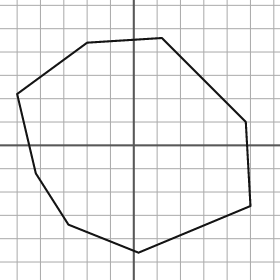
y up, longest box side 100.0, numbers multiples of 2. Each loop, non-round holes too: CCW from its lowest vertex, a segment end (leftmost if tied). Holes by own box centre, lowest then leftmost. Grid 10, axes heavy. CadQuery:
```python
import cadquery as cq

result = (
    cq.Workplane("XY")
    .moveTo(2.0, -46.0)
    .lineTo(50.0, -26.0)
    .lineTo(48.0, 10.0)
    .lineTo(12.0, 46.0)
    .lineTo(-20.0, 44.0)
    .lineTo(-50.0, 22.0)
    .lineTo(-42.0, -12.0)
    .lineTo(-28.0, -34.0)
    .close()
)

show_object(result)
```